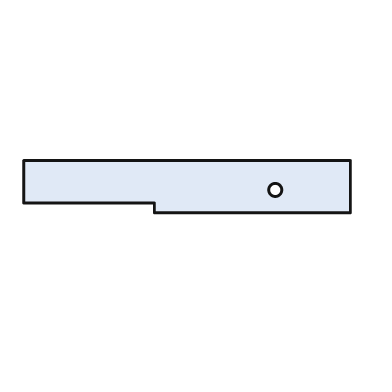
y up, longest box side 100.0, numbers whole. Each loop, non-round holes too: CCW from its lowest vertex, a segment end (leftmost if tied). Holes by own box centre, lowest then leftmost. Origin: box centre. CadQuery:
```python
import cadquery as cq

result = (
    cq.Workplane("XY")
    .moveTo(-10.0, -8.0)
    .lineTo(50.0, -8.0)
    .lineTo(50.0, 8.0)
    .lineTo(-50.0, 8.0)
    .lineTo(-50.0, -5.0)
    .lineTo(-10.0, -5.0)
    .close()
    .moveTo(27.0, -1.0)
    .circle(2.0)
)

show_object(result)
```